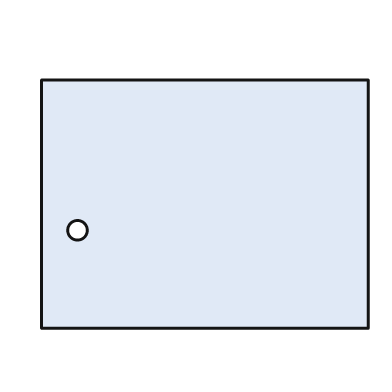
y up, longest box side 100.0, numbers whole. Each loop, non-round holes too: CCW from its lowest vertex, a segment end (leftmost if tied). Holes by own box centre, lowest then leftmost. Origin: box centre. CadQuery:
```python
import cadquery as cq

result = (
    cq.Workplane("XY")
    .moveTo(-50.0, -38.0)
    .lineTo(50.0, -38.0)
    .lineTo(50.0, 38.0)
    .lineTo(-50.0, 38.0)
    .close()
    .moveTo(-39.0, -8.0)
    .circle(3.0)
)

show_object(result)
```